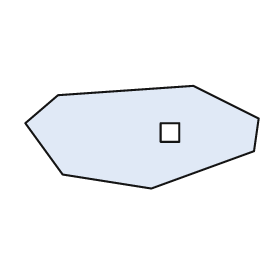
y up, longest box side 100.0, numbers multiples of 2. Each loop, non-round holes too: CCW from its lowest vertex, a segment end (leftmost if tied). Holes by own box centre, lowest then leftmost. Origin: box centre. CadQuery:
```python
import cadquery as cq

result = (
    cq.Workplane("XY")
    .moveTo(4.0, -22.0)
    .lineTo(48.0, -6.0)
    .lineTo(50.0, 8.0)
    .lineTo(22.0, 22.0)
    .lineTo(-36.0, 18.0)
    .lineTo(-50.0, 6.0)
    .lineTo(-34.0, -16.0)
    .close()
    .moveTo(8.0, -2.0)
    .lineTo(16.0, -2.0)
    .lineTo(16.0, 6.0)
    .lineTo(8.0, 6.0)
    .close()
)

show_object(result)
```